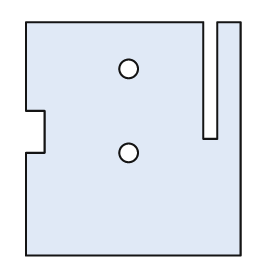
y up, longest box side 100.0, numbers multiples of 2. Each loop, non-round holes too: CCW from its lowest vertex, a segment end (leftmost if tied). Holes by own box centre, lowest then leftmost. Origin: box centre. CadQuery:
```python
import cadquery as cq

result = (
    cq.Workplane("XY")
    .moveTo(-46.0, -50.0)
    .lineTo(46.0, -50.0)
    .lineTo(46.0, 50.0)
    .lineTo(36.0, 50.0)
    .lineTo(36.0, 0.0)
    .lineTo(30.0, 0.0)
    .lineTo(30.0, 50.0)
    .lineTo(-46.0, 50.0)
    .lineTo(-46.0, 12.0)
    .lineTo(-38.0, 12.0)
    .lineTo(-38.0, -6.0)
    .lineTo(-46.0, -6.0)
    .close()
    .moveTo(-2.0, -6.0)
    .circle(4.0)
    .moveTo(-2.0, 30.0)
    .circle(4.0)
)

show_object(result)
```